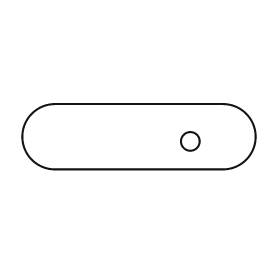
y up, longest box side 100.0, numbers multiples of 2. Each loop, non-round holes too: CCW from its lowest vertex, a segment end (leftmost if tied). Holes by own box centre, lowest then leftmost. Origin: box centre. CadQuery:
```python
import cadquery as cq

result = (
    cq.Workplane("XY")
    .moveTo(-36.0, -14.0)
    .lineTo(36.0, -14.0)
    .threePointArc((50.0, 0.0), (36.0, 14.0))
    .lineTo(-36.0, 14.0)
    .threePointArc((-50.0, 0.0), (-36.0, -14.0))
    .close()
    .moveTo(22.0, -2.0)
    .circle(4.0)
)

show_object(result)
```